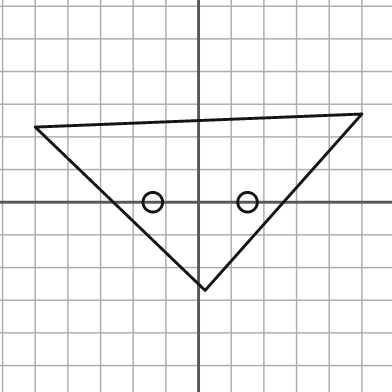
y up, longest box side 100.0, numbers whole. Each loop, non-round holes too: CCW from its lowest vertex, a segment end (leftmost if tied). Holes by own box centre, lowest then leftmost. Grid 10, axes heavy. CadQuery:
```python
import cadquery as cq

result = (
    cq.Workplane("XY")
    .moveTo(2.0, -27.0)
    .lineTo(50.0, 27.0)
    .lineTo(-50.0, 23.0)
    .close()
    .moveTo(-14.0, 0.0)
    .circle(3.0)
    .moveTo(15.0, 0.0)
    .circle(3.0)
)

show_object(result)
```